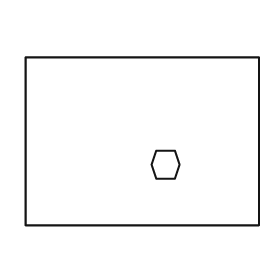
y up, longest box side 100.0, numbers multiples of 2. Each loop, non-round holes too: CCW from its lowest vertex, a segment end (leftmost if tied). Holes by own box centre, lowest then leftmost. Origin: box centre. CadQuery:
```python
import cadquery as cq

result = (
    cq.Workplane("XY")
    .moveTo(-50.0, -36.0)
    .lineTo(50.0, -36.0)
    .lineTo(50.0, 36.0)
    .lineTo(-50.0, 36.0)
    .close()
    .moveTo(6.0, -16.0)
    .lineTo(14.0, -16.0)
    .lineTo(16.0, -10.0)
    .lineTo(14.0, -4.0)
    .lineTo(6.0, -4.0)
    .lineTo(4.0, -10.0)
    .close()
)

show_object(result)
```